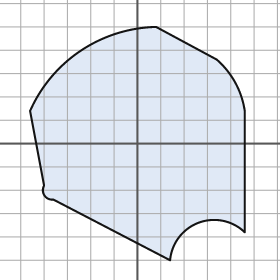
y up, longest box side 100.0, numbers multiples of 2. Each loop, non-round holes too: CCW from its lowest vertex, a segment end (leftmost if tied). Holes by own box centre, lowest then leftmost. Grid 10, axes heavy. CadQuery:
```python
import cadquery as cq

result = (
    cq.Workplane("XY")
    .moveTo(14.0, -50.0)
    .threePointArc((26.0, -34.0), (46.0, -38.0))
    .lineTo(46.0, 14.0)
    .threePointArc((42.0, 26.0), (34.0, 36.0))
    .lineTo(8.0, 50.0)
    .threePointArc((-24.0, 40.0), (-46.0, 14.0))
    .lineTo(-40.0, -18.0)
    .threePointArc((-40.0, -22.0), (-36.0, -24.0))
    .close()
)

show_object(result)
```